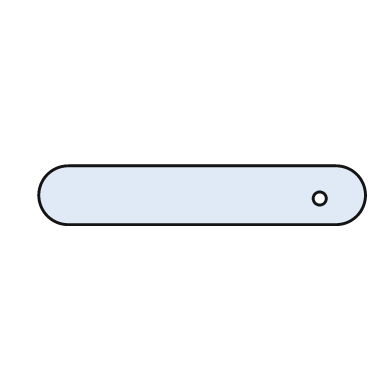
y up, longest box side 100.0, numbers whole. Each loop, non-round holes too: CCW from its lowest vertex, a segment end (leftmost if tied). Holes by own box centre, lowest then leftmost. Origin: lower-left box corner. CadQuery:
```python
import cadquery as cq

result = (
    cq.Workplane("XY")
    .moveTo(9.0, 0.0)
    .lineTo(91.0, 0.0)
    .threePointArc((100.0, 9.0), (91.0, 18.0))
    .lineTo(9.0, 18.0)
    .threePointArc((0.0, 9.0), (9.0, 0.0))
    .close()
    .moveTo(86.0, 8.0)
    .circle(2.0)
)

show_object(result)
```